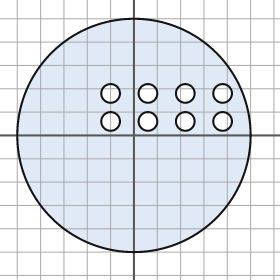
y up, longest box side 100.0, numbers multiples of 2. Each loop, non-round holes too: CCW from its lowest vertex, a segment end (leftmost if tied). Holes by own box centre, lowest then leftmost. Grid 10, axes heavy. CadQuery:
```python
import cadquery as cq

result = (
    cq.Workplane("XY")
    .moveTo(0.0, 0.0)
    .circle(50.0)
    .moveTo(-10.0, 6.0)
    .circle(4.0)
    .moveTo(6.0, 6.0)
    .circle(4.0)
    .moveTo(22.0, 6.0)
    .circle(4.0)
    .moveTo(38.0, 6.0)
    .circle(4.0)
    .moveTo(-10.0, 18.0)
    .circle(4.0)
    .moveTo(6.0, 18.0)
    .circle(4.0)
    .moveTo(22.0, 18.0)
    .circle(4.0)
    .moveTo(38.0, 18.0)
    .circle(4.0)
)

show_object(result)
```